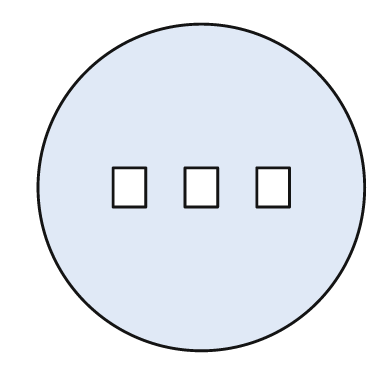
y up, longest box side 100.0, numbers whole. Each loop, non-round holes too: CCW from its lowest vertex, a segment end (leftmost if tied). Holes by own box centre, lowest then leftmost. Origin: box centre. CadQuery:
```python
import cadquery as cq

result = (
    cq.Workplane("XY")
    .moveTo(0.0, 0.0)
    .circle(50.0)
    .moveTo(-27.0, -6.0)
    .lineTo(-17.0, -6.0)
    .lineTo(-17.0, 6.0)
    .lineTo(-27.0, 6.0)
    .close()
    .moveTo(-5.0, -6.0)
    .lineTo(5.0, -6.0)
    .lineTo(5.0, 6.0)
    .lineTo(-5.0, 6.0)
    .close()
    .moveTo(17.0, -6.0)
    .lineTo(27.0, -6.0)
    .lineTo(27.0, 6.0)
    .lineTo(17.0, 6.0)
    .close()
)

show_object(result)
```